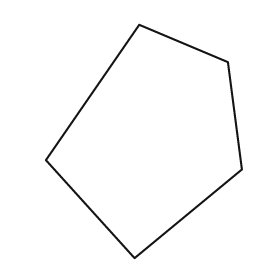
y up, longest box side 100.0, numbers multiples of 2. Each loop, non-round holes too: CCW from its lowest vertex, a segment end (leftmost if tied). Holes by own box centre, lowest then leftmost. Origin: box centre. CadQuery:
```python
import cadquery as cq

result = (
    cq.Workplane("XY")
    .moveTo(-4.0, -50.0)
    .lineTo(42.0, -12.0)
    .lineTo(36.0, 34.0)
    .lineTo(-2.0, 50.0)
    .lineTo(-42.0, -8.0)
    .close()
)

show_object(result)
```